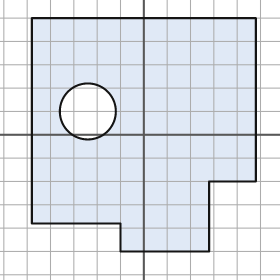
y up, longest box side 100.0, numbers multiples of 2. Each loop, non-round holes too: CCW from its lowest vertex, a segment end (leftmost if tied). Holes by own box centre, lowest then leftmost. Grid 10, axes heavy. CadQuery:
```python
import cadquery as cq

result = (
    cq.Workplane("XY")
    .moveTo(-10.0, -50.0)
    .lineTo(28.0, -50.0)
    .lineTo(28.0, -20.0)
    .lineTo(48.0, -20.0)
    .lineTo(48.0, 50.0)
    .lineTo(-48.0, 50.0)
    .lineTo(-48.0, -38.0)
    .lineTo(-10.0, -38.0)
    .close()
    .moveTo(-24.0, 10.0)
    .circle(12.0)
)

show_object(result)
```